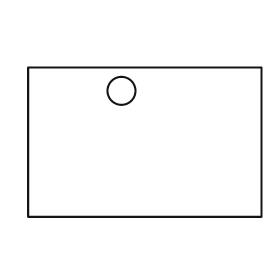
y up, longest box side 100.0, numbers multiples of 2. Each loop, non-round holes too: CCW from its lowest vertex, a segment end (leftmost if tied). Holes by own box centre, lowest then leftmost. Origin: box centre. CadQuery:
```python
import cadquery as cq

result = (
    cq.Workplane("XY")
    .moveTo(-50.0, -32.0)
    .lineTo(50.0, -32.0)
    .lineTo(50.0, 32.0)
    .lineTo(-50.0, 32.0)
    .close()
    .moveTo(-10.0, 22.0)
    .circle(6.0)
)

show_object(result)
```